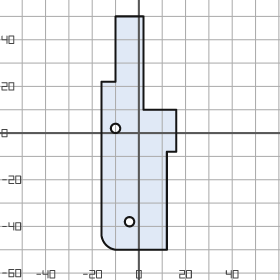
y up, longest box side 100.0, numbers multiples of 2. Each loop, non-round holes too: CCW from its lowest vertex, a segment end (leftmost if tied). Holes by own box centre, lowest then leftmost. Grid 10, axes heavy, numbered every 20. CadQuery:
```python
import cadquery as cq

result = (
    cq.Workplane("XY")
    .moveTo(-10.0, -50.0)
    .lineTo(12.0, -50.0)
    .lineTo(12.0, -8.0)
    .lineTo(16.0, -8.0)
    .lineTo(16.0, 10.0)
    .lineTo(2.0, 10.0)
    .lineTo(2.0, 50.0)
    .lineTo(-10.0, 50.0)
    .lineTo(-10.0, 22.0)
    .lineTo(-16.0, 22.0)
    .lineTo(-16.0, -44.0)
    .threePointArc((-14.0, -48.0), (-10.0, -50.0))
    .close()
    .moveTo(-4.0, -38.0)
    .circle(2.0)
    .moveTo(-10.0, 2.0)
    .circle(2.0)
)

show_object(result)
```